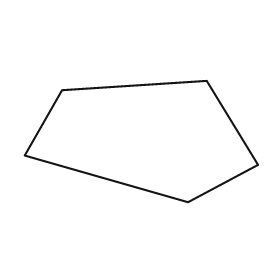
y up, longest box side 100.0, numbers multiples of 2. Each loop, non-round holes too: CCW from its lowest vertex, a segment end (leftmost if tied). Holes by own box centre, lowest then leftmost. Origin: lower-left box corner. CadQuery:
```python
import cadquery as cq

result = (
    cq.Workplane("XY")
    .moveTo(70.0, 0.0)
    .lineTo(100.0, 16.0)
    .lineTo(78.0, 52.0)
    .lineTo(16.0, 48.0)
    .lineTo(0.0, 20.0)
    .close()
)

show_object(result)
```